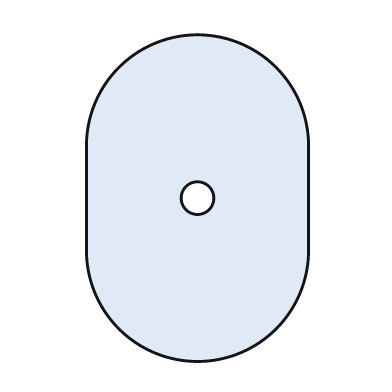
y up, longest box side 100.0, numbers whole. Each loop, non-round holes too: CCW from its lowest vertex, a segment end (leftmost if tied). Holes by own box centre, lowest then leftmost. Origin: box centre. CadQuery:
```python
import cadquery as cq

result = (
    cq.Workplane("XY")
    .moveTo(-34.0, -16.0)
    .threePointArc((0.0, -50.0), (34.0, -16.0))
    .lineTo(34.0, 16.0)
    .threePointArc((0.0, 50.0), (-34.0, 16.0))
    .close()
    .moveTo(0.0, 0.0)
    .circle(5.0)
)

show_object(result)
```